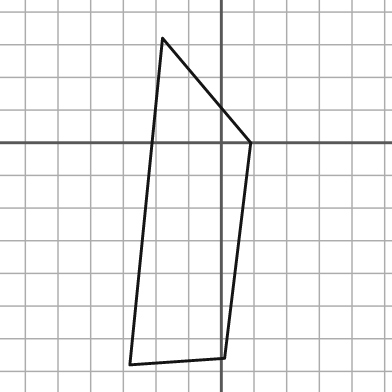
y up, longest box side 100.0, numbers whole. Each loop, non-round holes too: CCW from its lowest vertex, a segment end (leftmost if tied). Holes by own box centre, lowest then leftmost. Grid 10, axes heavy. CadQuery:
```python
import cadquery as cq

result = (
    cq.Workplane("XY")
    .moveTo(-28.0, -68.0)
    .lineTo(1.0, -66.0)
    .lineTo(9.0, 0.0)
    .lineTo(-18.0, 32.0)
    .close()
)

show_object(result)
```